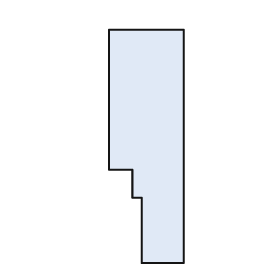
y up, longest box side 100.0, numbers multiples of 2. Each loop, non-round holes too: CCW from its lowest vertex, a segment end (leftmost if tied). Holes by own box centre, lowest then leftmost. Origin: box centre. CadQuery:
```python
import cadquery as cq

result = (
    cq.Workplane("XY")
    .moveTo(-2.0, -50.0)
    .lineTo(16.0, -50.0)
    .lineTo(16.0, 50.0)
    .lineTo(-16.0, 50.0)
    .lineTo(-16.0, -10.0)
    .lineTo(-6.0, -10.0)
    .lineTo(-6.0, -22.0)
    .lineTo(-2.0, -22.0)
    .close()
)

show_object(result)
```